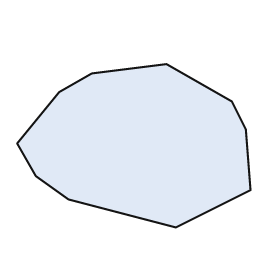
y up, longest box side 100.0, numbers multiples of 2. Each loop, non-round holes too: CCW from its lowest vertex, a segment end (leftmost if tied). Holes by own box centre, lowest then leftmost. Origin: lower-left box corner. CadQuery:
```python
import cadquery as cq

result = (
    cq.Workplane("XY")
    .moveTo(68.0, 0.0)
    .lineTo(100.0, 16.0)
    .lineTo(98.0, 42.0)
    .lineTo(92.0, 54.0)
    .lineTo(64.0, 70.0)
    .lineTo(32.0, 66.0)
    .lineTo(18.0, 58.0)
    .lineTo(0.0, 36.0)
    .lineTo(8.0, 22.0)
    .lineTo(22.0, 12.0)
    .close()
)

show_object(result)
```